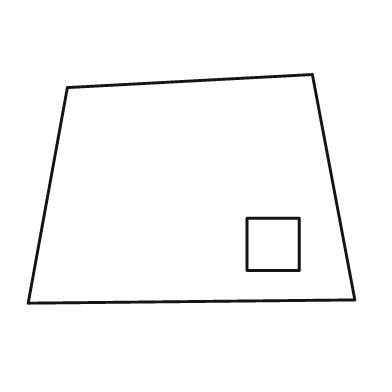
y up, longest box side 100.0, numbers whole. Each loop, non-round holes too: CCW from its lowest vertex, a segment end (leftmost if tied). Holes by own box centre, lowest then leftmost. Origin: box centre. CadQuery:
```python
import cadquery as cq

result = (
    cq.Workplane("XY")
    .moveTo(-50.0, -35.0)
    .lineTo(50.0, -34.0)
    .lineTo(37.0, 35.0)
    .lineTo(-38.0, 31.0)
    .close()
    .moveTo(17.0, -25.0)
    .lineTo(33.0, -25.0)
    .lineTo(33.0, -9.0)
    .lineTo(17.0, -9.0)
    .close()
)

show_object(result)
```